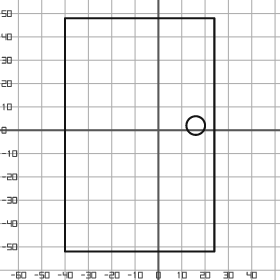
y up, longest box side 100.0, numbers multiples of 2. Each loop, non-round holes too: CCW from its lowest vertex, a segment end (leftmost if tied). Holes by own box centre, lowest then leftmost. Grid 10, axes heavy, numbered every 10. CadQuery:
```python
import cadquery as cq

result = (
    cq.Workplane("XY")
    .moveTo(-40.0, -52.0)
    .lineTo(24.0, -52.0)
    .lineTo(24.0, 48.0)
    .lineTo(-40.0, 48.0)
    .close()
    .moveTo(16.0, 2.0)
    .circle(4.0)
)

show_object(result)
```